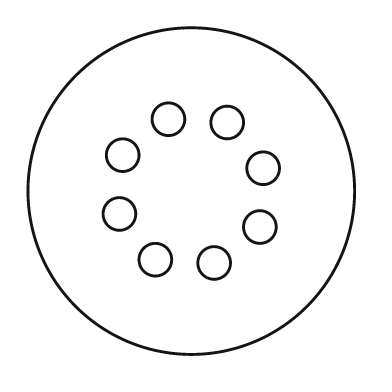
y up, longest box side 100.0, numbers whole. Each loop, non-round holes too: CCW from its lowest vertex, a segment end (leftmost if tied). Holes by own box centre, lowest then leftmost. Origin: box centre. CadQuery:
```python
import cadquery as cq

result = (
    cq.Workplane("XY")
    .moveTo(0.0, 0.0)
    .circle(50.0)
    .moveTo(7.0, -22.0)
    .circle(5.0)
    .moveTo(-11.0, -21.0)
    .circle(5.0)
    .moveTo(21.0, -11.0)
    .circle(5.0)
    .moveTo(-22.0, -7.0)
    .circle(5.0)
    .moveTo(22.0, 7.0)
    .circle(5.0)
    .moveTo(-21.0, 11.0)
    .circle(5.0)
    .moveTo(11.0, 21.0)
    .circle(5.0)
    .moveTo(-7.0, 22.0)
    .circle(5.0)
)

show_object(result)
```